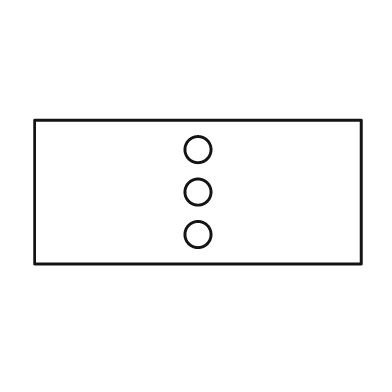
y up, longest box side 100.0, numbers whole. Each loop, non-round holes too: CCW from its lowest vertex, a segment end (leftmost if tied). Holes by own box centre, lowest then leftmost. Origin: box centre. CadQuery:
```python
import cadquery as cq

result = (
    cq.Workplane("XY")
    .moveTo(-50.0, -22.0)
    .lineTo(50.0, -22.0)
    .lineTo(50.0, 22.0)
    .lineTo(-50.0, 22.0)
    .close()
    .moveTo(0.0, -13.0)
    .circle(4.0)
    .moveTo(0.0, 0.0)
    .circle(4.0)
    .moveTo(0.0, 13.0)
    .circle(4.0)
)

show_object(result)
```